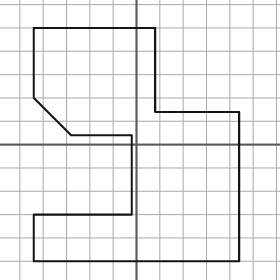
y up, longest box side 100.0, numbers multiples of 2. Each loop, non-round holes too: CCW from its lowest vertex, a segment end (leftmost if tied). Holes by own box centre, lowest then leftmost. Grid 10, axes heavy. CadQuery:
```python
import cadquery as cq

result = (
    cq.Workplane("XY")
    .moveTo(-44.0, -50.0)
    .lineTo(44.0, -50.0)
    .lineTo(44.0, 14.0)
    .lineTo(8.0, 14.0)
    .lineTo(8.0, 50.0)
    .lineTo(-44.0, 50.0)
    .lineTo(-44.0, 20.0)
    .lineTo(-28.0, 4.0)
    .lineTo(-2.0, 4.0)
    .lineTo(-2.0, -30.0)
    .lineTo(-44.0, -30.0)
    .close()
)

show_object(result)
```